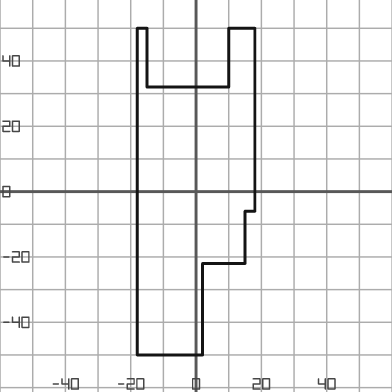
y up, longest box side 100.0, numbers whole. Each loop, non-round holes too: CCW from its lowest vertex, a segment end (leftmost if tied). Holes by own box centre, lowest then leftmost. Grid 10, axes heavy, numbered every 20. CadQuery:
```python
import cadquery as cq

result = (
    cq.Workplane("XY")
    .moveTo(-18.0, -50.0)
    .lineTo(2.0, -50.0)
    .lineTo(2.0, -22.0)
    .lineTo(15.0, -22.0)
    .lineTo(15.0, -6.0)
    .lineTo(18.0, -6.0)
    .lineTo(18.0, 50.0)
    .lineTo(10.0, 50.0)
    .lineTo(10.0, 32.0)
    .lineTo(-15.0, 32.0)
    .lineTo(-15.0, 50.0)
    .lineTo(-18.0, 50.0)
    .close()
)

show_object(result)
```